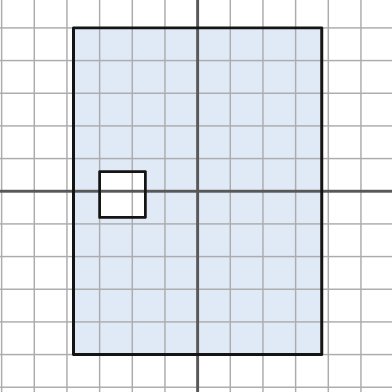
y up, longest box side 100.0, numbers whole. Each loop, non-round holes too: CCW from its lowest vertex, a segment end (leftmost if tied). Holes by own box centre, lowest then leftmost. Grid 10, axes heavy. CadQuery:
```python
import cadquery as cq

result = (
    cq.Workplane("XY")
    .moveTo(-38.0, -50.0)
    .lineTo(38.0, -50.0)
    .lineTo(38.0, 50.0)
    .lineTo(-38.0, 50.0)
    .close()
    .moveTo(-30.0, -8.0)
    .lineTo(-16.0, -8.0)
    .lineTo(-16.0, 6.0)
    .lineTo(-30.0, 6.0)
    .close()
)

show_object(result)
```